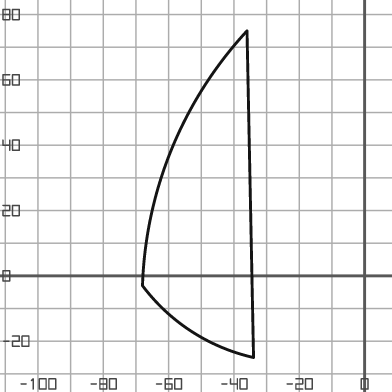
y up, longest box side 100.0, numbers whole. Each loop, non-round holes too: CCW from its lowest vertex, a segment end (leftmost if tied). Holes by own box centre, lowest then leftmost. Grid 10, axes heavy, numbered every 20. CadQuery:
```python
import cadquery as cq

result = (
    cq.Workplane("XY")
    .moveTo(-34.0, -25.0)
    .lineTo(-36.0, 75.0)
    .threePointArc((-59.0, 39.0), (-68.0, -3.0))
    .threePointArc((-53.0, -17.0), (-34.0, -25.0))
    .close()
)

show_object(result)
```